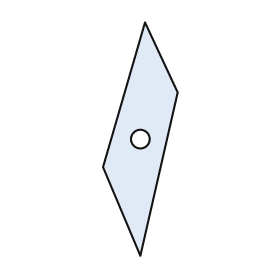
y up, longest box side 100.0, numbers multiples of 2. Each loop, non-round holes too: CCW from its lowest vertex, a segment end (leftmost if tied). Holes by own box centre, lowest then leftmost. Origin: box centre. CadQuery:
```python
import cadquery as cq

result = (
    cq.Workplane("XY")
    .moveTo(0.0, -50.0)
    .lineTo(16.0, 20.0)
    .lineTo(2.0, 50.0)
    .lineTo(-16.0, -12.0)
    .close()
    .moveTo(0.0, 0.0)
    .circle(4.0)
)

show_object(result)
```